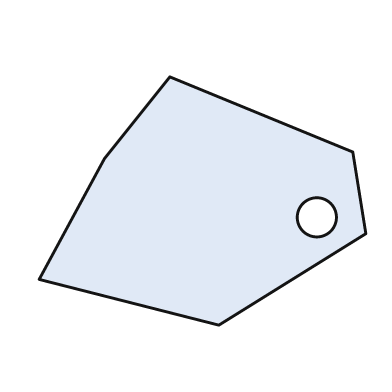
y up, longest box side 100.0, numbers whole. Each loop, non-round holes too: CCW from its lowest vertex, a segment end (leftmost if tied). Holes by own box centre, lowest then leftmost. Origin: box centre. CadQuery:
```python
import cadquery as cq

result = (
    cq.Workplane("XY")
    .moveTo(5.0, -38.0)
    .lineTo(50.0, -10.0)
    .lineTo(46.0, 15.0)
    .lineTo(-10.0, 38.0)
    .lineTo(-30.0, 13.0)
    .lineTo(-50.0, -24.0)
    .close()
    .moveTo(35.0, -5.0)
    .circle(6.0)
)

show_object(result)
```